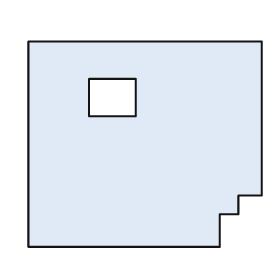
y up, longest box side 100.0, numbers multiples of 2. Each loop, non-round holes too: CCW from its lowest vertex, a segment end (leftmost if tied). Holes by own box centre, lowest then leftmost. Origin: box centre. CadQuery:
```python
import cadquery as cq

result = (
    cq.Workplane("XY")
    .moveTo(-50.0, -44.0)
    .lineTo(32.0, -44.0)
    .lineTo(32.0, -30.0)
    .lineTo(40.0, -30.0)
    .lineTo(40.0, -22.0)
    .lineTo(50.0, -22.0)
    .lineTo(50.0, 44.0)
    .lineTo(-50.0, 44.0)
    .close()
    .moveTo(-24.0, 12.0)
    .lineTo(-4.0, 12.0)
    .lineTo(-4.0, 28.0)
    .lineTo(-24.0, 28.0)
    .close()
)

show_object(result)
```